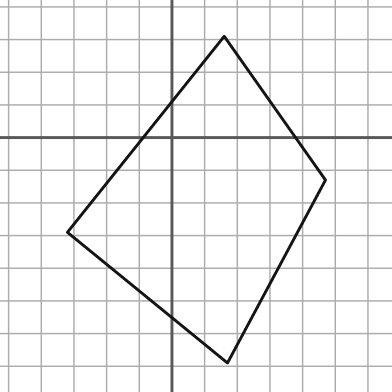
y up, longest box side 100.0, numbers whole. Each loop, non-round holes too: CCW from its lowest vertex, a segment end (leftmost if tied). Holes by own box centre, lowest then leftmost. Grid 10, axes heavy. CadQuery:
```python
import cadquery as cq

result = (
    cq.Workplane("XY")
    .moveTo(17.0, -69.0)
    .lineTo(47.0, -13.0)
    .lineTo(16.0, 31.0)
    .lineTo(-32.0, -29.0)
    .close()
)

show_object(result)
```